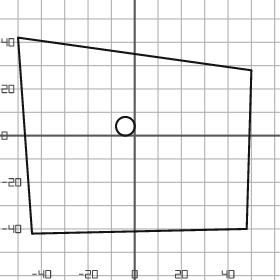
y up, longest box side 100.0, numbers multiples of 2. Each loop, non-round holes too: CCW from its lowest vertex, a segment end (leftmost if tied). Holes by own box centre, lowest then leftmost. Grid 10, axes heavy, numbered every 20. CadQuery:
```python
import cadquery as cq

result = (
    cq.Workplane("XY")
    .moveTo(-44.0, -42.0)
    .lineTo(48.0, -40.0)
    .lineTo(50.0, 28.0)
    .lineTo(-50.0, 42.0)
    .close()
    .moveTo(-4.0, 4.0)
    .circle(4.0)
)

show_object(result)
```